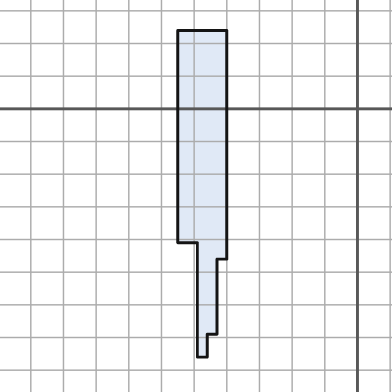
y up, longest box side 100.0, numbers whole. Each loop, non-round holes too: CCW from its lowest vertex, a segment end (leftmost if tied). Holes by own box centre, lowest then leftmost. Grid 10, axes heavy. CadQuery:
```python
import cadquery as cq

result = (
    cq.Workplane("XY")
    .moveTo(-49.0, -76.0)
    .lineTo(-46.0, -76.0)
    .lineTo(-46.0, -69.0)
    .lineTo(-43.0, -69.0)
    .lineTo(-43.0, -46.0)
    .lineTo(-40.0, -46.0)
    .lineTo(-40.0, 24.0)
    .lineTo(-55.0, 24.0)
    .lineTo(-55.0, -41.0)
    .lineTo(-49.0, -41.0)
    .close()
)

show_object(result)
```